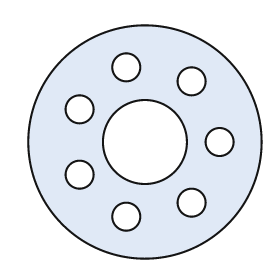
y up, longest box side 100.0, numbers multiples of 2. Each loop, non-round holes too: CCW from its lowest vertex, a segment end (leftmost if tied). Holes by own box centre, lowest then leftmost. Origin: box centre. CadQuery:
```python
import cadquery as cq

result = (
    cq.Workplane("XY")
    .moveTo(0.0, 0.0)
    .circle(50.0)
    .moveTo(-8.0, -32.0)
    .circle(6.0)
    .moveTo(20.0, -26.0)
    .circle(6.0)
    .moveTo(-28.0, -14.0)
    .circle(6.0)
    .moveTo(0.0, 0.0)
    .circle(18.0)
    .moveTo(32.0, 0.0)
    .circle(6.0)
    .moveTo(-28.0, 14.0)
    .circle(6.0)
    .moveTo(20.0, 26.0)
    .circle(6.0)
    .moveTo(-8.0, 32.0)
    .circle(6.0)
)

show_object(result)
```